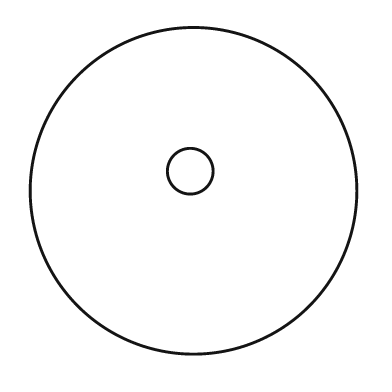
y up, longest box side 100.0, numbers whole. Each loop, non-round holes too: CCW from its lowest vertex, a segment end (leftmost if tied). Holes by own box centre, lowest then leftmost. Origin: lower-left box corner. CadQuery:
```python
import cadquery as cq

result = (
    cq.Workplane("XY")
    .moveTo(50.0, 50.0)
    .circle(50.0)
    .moveTo(49.0, 56.0)
    .circle(7.0)
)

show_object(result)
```